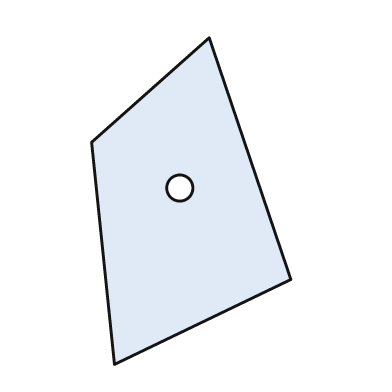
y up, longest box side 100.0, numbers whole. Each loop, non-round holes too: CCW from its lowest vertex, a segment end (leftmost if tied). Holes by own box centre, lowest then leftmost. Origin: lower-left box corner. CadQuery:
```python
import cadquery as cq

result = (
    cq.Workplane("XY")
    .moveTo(7.0, 0.0)
    .lineTo(61.0, 26.0)
    .lineTo(36.0, 100.0)
    .lineTo(0.0, 68.0)
    .close()
    .moveTo(27.0, 54.0)
    .circle(4.0)
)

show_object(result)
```